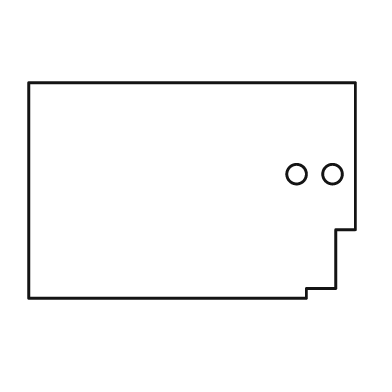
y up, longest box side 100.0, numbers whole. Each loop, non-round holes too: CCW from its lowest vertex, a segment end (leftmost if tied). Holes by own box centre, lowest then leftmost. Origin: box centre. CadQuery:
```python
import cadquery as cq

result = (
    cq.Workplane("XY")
    .moveTo(-50.0, -33.0)
    .lineTo(35.0, -33.0)
    .lineTo(35.0, -30.0)
    .lineTo(44.0, -30.0)
    .lineTo(44.0, -12.0)
    .lineTo(50.0, -12.0)
    .lineTo(50.0, 33.0)
    .lineTo(-50.0, 33.0)
    .close()
    .moveTo(32.0, 5.0)
    .circle(3.0)
    .moveTo(43.0, 5.0)
    .circle(3.0)
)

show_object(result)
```